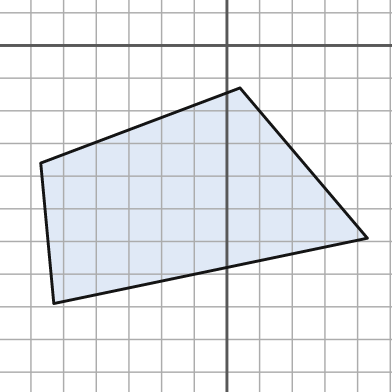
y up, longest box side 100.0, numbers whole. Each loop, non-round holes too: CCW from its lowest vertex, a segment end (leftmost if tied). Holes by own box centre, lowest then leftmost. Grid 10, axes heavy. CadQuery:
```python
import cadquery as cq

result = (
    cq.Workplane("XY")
    .moveTo(-53.0, -79.0)
    .lineTo(43.0, -59.0)
    .lineTo(4.0, -13.0)
    .lineTo(-57.0, -36.0)
    .close()
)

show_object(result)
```